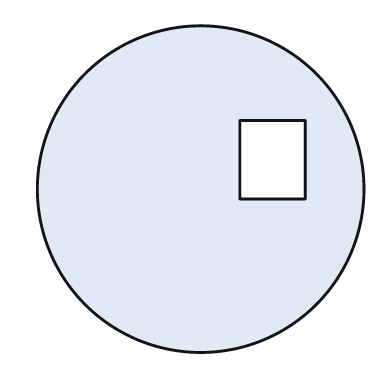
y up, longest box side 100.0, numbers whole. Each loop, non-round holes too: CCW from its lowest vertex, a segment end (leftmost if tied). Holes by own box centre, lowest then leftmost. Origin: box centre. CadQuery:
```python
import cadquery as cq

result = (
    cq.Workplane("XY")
    .moveTo(0.0, 0.0)
    .circle(50.0)
    .moveTo(12.0, -3.0)
    .lineTo(32.0, -3.0)
    .lineTo(32.0, 21.0)
    .lineTo(12.0, 21.0)
    .close()
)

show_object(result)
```